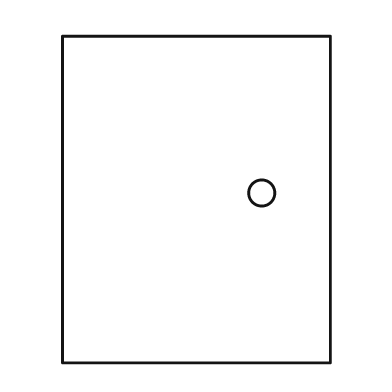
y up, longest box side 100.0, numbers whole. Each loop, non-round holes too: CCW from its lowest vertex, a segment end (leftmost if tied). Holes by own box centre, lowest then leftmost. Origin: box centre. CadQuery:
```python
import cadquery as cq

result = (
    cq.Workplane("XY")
    .moveTo(-41.0, -50.0)
    .lineTo(41.0, -50.0)
    .lineTo(41.0, 50.0)
    .lineTo(-41.0, 50.0)
    .close()
    .moveTo(20.0, 2.0)
    .circle(4.0)
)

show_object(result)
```